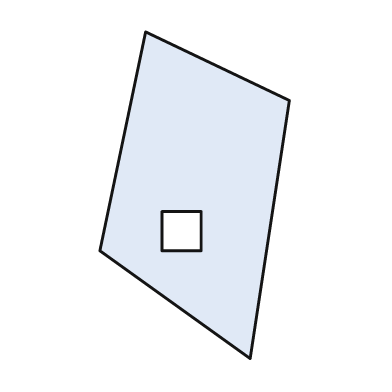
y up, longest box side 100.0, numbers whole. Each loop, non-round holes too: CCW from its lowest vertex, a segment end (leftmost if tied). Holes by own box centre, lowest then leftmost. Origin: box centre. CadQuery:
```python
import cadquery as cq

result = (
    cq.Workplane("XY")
    .moveTo(17.0, -50.0)
    .lineTo(29.0, 29.0)
    .lineTo(-15.0, 50.0)
    .lineTo(-29.0, -17.0)
    .close()
    .moveTo(-10.0, -17.0)
    .lineTo(2.0, -17.0)
    .lineTo(2.0, -5.0)
    .lineTo(-10.0, -5.0)
    .close()
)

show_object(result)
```